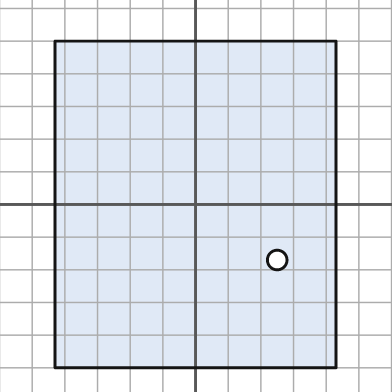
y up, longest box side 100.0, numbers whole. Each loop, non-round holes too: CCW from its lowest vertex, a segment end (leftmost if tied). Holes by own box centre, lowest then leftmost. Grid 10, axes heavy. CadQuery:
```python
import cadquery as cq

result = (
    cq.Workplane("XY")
    .moveTo(-43.0, -50.0)
    .lineTo(43.0, -50.0)
    .lineTo(43.0, 50.0)
    .lineTo(-43.0, 50.0)
    .close()
    .moveTo(25.0, -17.0)
    .circle(3.0)
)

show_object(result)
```